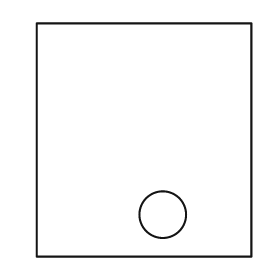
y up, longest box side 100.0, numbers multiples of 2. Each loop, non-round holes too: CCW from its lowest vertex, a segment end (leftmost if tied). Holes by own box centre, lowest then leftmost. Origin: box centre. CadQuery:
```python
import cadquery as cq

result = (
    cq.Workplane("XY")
    .moveTo(-46.0, -50.0)
    .lineTo(46.0, -50.0)
    .lineTo(46.0, 50.0)
    .lineTo(-46.0, 50.0)
    .close()
    .moveTo(8.0, -32.0)
    .circle(10.0)
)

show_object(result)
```